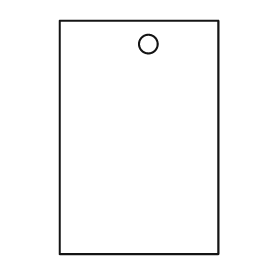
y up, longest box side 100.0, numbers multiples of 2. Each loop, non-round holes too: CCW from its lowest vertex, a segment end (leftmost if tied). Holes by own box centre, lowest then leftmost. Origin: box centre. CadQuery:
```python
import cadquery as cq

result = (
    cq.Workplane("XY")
    .moveTo(-34.0, -50.0)
    .lineTo(34.0, -50.0)
    .lineTo(34.0, 50.0)
    .lineTo(-34.0, 50.0)
    .close()
    .moveTo(4.0, 40.0)
    .circle(4.0)
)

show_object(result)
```